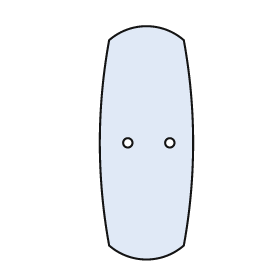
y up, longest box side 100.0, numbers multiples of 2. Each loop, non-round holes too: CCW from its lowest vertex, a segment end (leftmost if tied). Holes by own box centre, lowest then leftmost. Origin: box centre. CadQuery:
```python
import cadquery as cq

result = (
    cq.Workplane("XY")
    .moveTo(-16.0, -44.0)
    .threePointArc((0.0, -50.0), (16.0, -44.0))
    .threePointArc((20.0, 0.0), (16.0, 44.0))
    .threePointArc((0.0, 50.0), (-16.0, 44.0))
    .threePointArc((-20.0, 0.0), (-16.0, -44.0))
    .close()
    .moveTo(-8.0, 0.0)
    .circle(2.0)
    .moveTo(10.0, 0.0)
    .circle(2.0)
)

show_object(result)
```